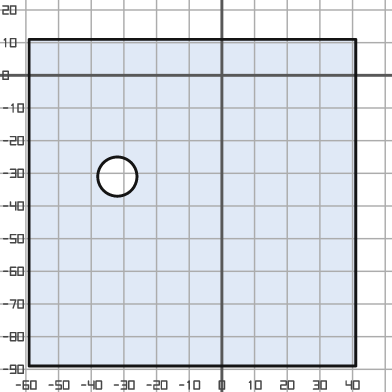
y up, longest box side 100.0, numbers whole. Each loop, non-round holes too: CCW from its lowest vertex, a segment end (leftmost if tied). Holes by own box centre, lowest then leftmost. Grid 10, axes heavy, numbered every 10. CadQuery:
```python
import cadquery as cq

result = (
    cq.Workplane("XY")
    .moveTo(-59.0, -89.0)
    .lineTo(41.0, -89.0)
    .lineTo(41.0, 11.0)
    .lineTo(-59.0, 11.0)
    .close()
    .moveTo(-32.0, -31.0)
    .circle(6.0)
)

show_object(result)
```